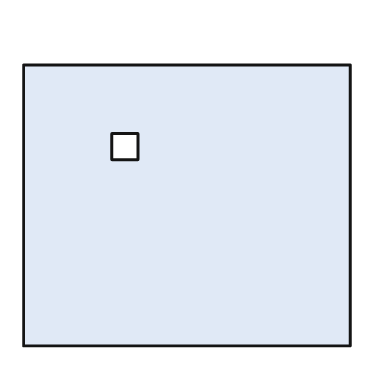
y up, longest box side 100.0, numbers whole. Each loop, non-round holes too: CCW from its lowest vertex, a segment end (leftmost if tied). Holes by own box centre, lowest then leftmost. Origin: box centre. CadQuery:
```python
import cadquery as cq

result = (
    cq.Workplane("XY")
    .moveTo(-50.0, -43.0)
    .lineTo(50.0, -43.0)
    .lineTo(50.0, 43.0)
    .lineTo(-50.0, 43.0)
    .close()
    .moveTo(-23.0, 14.0)
    .lineTo(-15.0, 14.0)
    .lineTo(-15.0, 22.0)
    .lineTo(-23.0, 22.0)
    .close()
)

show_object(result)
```